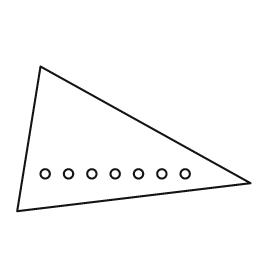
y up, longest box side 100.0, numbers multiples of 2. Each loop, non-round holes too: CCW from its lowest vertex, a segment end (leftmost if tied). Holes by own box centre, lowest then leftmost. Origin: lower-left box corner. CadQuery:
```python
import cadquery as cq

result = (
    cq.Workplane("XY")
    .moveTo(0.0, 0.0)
    .lineTo(100.0, 12.0)
    .lineTo(10.0, 62.0)
    .close()
    .moveTo(12.0, 16.0)
    .circle(2.0)
    .moveTo(22.0, 16.0)
    .circle(2.0)
    .moveTo(32.0, 16.0)
    .circle(2.0)
    .moveTo(42.0, 16.0)
    .circle(2.0)
    .moveTo(52.0, 16.0)
    .circle(2.0)
    .moveTo(62.0, 16.0)
    .circle(2.0)
    .moveTo(72.0, 16.0)
    .circle(2.0)
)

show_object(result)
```